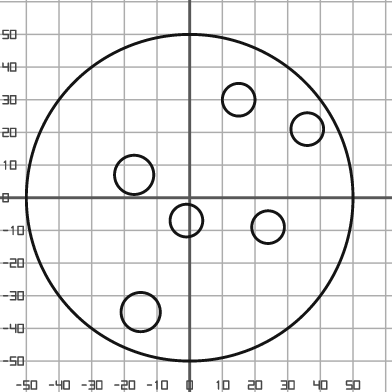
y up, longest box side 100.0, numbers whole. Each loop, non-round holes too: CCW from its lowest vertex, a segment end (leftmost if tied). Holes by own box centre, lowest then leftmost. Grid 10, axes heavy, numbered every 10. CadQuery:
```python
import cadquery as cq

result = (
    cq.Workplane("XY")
    .moveTo(0.0, 0.0)
    .circle(50.0)
    .moveTo(-15.0, -35.0)
    .circle(6.0)
    .moveTo(24.0, -9.0)
    .circle(5.0)
    .moveTo(-1.0, -7.0)
    .circle(5.0)
    .moveTo(-17.0, 7.0)
    .circle(6.0)
    .moveTo(36.0, 21.0)
    .circle(5.0)
    .moveTo(15.0, 30.0)
    .circle(5.0)
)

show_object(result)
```